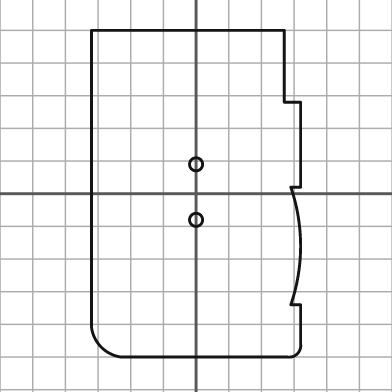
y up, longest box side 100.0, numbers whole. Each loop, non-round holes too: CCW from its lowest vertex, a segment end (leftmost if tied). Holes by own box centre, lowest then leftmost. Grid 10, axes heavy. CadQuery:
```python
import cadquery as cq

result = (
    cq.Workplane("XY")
    .moveTo(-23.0, -50.0)
    .lineTo(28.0, -50.0)
    .threePointArc((31.0, -49.0), (32.0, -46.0))
    .lineTo(32.0, -34.0)
    .lineTo(29.0, -34.0)
    .threePointArc((32.0, -16.0), (29.0, 2.0))
    .lineTo(32.0, 2.0)
    .lineTo(32.0, 28.0)
    .lineTo(27.0, 28.0)
    .lineTo(27.0, 50.0)
    .lineTo(-32.0, 50.0)
    .lineTo(-32.0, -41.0)
    .threePointArc((-29.0, -47.0), (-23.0, -50.0))
    .close()
    .moveTo(0.0, -8.0)
    .circle(2.0)
    .moveTo(0.0, 9.0)
    .circle(2.0)
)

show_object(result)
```